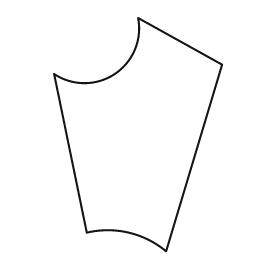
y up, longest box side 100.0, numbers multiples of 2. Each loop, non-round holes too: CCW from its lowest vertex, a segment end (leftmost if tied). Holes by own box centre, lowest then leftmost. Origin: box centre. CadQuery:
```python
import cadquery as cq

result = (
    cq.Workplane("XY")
    .moveTo(12.0, -50.0)
    .lineTo(36.0, 30.0)
    .lineTo(0.0, 50.0)
    .threePointArc((-10.0, 26.0), (-36.0, 26.0))
    .lineTo(-22.0, -42.0)
    .threePointArc((-4.0, -42.0), (12.0, -50.0))
    .close()
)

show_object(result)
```